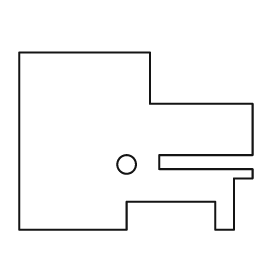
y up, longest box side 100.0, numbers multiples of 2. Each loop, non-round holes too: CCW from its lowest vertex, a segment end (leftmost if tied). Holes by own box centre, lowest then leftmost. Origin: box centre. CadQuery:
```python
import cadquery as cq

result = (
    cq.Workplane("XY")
    .moveTo(-50.0, -38.0)
    .lineTo(-4.0, -38.0)
    .lineTo(-4.0, -26.0)
    .lineTo(34.0, -26.0)
    .lineTo(34.0, -38.0)
    .lineTo(42.0, -38.0)
    .lineTo(42.0, -16.0)
    .lineTo(50.0, -16.0)
    .lineTo(50.0, -12.0)
    .lineTo(10.0, -12.0)
    .lineTo(10.0, -6.0)
    .lineTo(50.0, -6.0)
    .lineTo(50.0, 16.0)
    .lineTo(6.0, 16.0)
    .lineTo(6.0, 38.0)
    .lineTo(-50.0, 38.0)
    .close()
    .moveTo(-4.0, -10.0)
    .circle(4.0)
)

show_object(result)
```